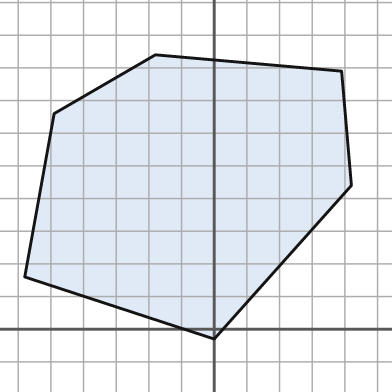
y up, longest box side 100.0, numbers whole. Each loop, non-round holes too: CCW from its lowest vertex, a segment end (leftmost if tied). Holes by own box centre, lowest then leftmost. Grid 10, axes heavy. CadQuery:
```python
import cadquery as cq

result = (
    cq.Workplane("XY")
    .moveTo(0.0, -3.0)
    .lineTo(42.0, 44.0)
    .lineTo(39.0, 79.0)
    .lineTo(-18.0, 84.0)
    .lineTo(-49.0, 66.0)
    .lineTo(-58.0, 16.0)
    .close()
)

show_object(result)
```